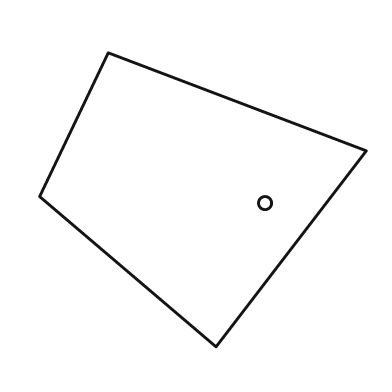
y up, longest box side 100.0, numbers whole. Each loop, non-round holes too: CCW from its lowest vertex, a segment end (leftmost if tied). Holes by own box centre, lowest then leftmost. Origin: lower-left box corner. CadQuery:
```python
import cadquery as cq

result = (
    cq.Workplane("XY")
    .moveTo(54.0, 0.0)
    .lineTo(100.0, 60.0)
    .lineTo(21.0, 90.0)
    .lineTo(0.0, 46.0)
    .close()
    .moveTo(69.0, 44.0)
    .circle(2.0)
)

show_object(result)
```